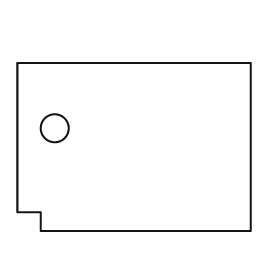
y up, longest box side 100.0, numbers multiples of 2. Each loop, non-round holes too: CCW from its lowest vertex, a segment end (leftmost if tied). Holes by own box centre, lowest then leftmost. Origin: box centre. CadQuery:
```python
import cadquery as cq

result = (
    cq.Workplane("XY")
    .moveTo(-40.0, -36.0)
    .lineTo(50.0, -36.0)
    .lineTo(50.0, 36.0)
    .lineTo(-50.0, 36.0)
    .lineTo(-50.0, -28.0)
    .lineTo(-40.0, -28.0)
    .close()
    .moveTo(-34.0, 8.0)
    .circle(6.0)
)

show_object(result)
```